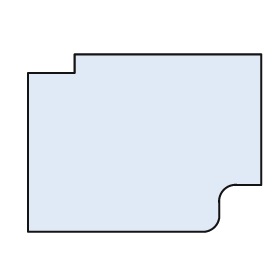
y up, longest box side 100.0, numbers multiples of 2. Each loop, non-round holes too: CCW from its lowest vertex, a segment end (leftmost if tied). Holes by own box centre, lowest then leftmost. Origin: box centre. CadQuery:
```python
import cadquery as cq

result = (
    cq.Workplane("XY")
    .moveTo(-50.0, -38.0)
    .lineTo(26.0, -38.0)
    .threePointArc((30.0, -36.0), (32.0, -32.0))
    .lineTo(32.0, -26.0)
    .threePointArc((34.0, -20.0), (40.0, -18.0))
    .lineTo(50.0, -18.0)
    .lineTo(50.0, 38.0)
    .lineTo(-30.0, 38.0)
    .lineTo(-30.0, 30.0)
    .lineTo(-50.0, 30.0)
    .close()
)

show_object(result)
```